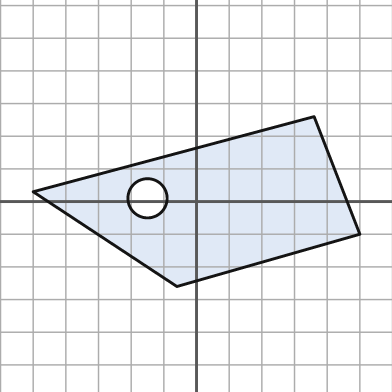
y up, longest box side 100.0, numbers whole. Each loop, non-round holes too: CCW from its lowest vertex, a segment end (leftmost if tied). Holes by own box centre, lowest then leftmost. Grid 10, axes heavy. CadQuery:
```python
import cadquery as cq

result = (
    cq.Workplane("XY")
    .moveTo(-6.0, -26.0)
    .lineTo(50.0, -10.0)
    .lineTo(36.0, 26.0)
    .lineTo(-50.0, 3.0)
    .close()
    .moveTo(-15.0, 1.0)
    .circle(6.0)
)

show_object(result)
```